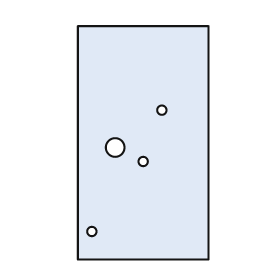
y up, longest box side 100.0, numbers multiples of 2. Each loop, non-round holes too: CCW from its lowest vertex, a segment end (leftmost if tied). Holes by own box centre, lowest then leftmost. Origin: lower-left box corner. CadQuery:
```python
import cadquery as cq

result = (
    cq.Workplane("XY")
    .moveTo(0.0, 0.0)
    .lineTo(56.0, 0.0)
    .lineTo(56.0, 100.0)
    .lineTo(0.0, 100.0)
    .close()
    .moveTo(6.0, 12.0)
    .circle(2.0)
    .moveTo(28.0, 42.0)
    .circle(2.0)
    .moveTo(16.0, 48.0)
    .circle(4.0)
    .moveTo(36.0, 64.0)
    .circle(2.0)
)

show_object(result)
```